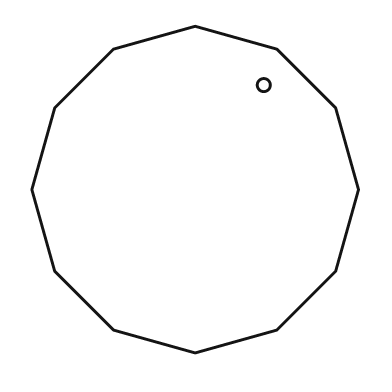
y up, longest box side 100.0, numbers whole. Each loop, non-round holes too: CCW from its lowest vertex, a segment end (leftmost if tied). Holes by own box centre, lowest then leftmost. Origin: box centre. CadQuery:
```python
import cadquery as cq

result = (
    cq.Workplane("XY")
    .moveTo(0.0, -50.0)
    .lineTo(25.0, -43.0)
    .lineTo(43.0, -25.0)
    .lineTo(50.0, 0.0)
    .lineTo(43.0, 25.0)
    .lineTo(25.0, 43.0)
    .lineTo(0.0, 50.0)
    .lineTo(-25.0, 43.0)
    .lineTo(-43.0, 25.0)
    .lineTo(-50.0, 0.0)
    .lineTo(-43.0, -25.0)
    .lineTo(-25.0, -43.0)
    .close()
    .moveTo(21.0, 32.0)
    .circle(2.0)
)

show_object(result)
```